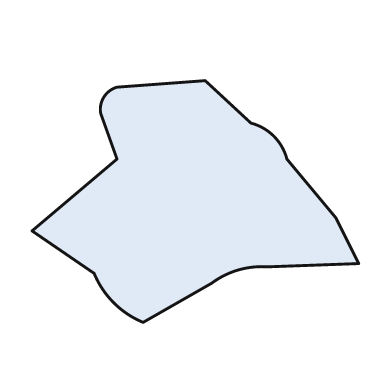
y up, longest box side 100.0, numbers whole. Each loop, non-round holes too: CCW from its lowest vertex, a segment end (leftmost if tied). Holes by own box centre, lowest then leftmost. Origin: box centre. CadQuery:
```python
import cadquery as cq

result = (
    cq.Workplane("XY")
    .moveTo(-16.0, -37.0)
    .lineTo(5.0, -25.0)
    .threePointArc((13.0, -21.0), (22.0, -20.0))
    .lineTo(50.0, -19.0)
    .lineTo(43.0, -5.0)
    .lineTo(28.0, 13.0)
    .threePointArc((24.0, 20.0), (17.0, 24.0))
    .lineTo(3.0, 37.0)
    .lineTo(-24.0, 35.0)
    .threePointArc((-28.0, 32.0), (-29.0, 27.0))
    .lineTo(-24.0, 13.0)
    .lineTo(-50.0, -9.0)
    .lineTo(-31.0, -22.0)
    .threePointArc((-25.0, -31.0), (-16.0, -37.0))
    .close()
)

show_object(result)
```